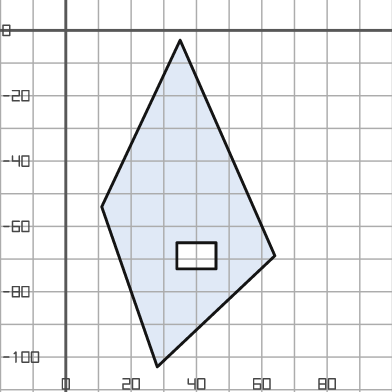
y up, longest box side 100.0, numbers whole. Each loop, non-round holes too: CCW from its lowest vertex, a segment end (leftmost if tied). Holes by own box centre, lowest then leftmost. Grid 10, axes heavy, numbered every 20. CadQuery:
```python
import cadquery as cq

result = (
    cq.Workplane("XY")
    .moveTo(28.0, -103.0)
    .lineTo(64.0, -69.0)
    .lineTo(35.0, -3.0)
    .lineTo(11.0, -54.0)
    .close()
    .moveTo(34.0, -73.0)
    .lineTo(46.0, -73.0)
    .lineTo(46.0, -65.0)
    .lineTo(34.0, -65.0)
    .close()
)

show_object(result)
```